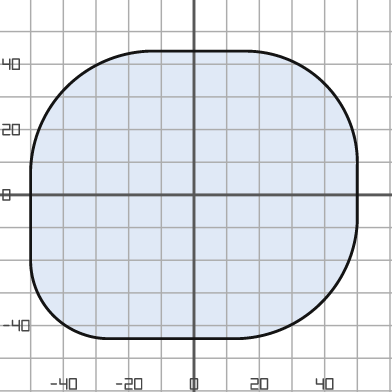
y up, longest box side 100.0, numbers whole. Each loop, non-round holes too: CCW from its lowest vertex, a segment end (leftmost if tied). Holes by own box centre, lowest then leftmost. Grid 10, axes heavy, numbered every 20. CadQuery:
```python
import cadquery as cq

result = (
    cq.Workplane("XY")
    .moveTo(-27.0, -44.0)
    .lineTo(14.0, -44.0)
    .threePointArc((39.0, -33.0), (50.0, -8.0))
    .lineTo(50.0, 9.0)
    .threePointArc((40.0, 34.0), (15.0, 44.0))
    .lineTo(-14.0, 44.0)
    .threePointArc((-39.0, 33.0), (-50.0, 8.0))
    .lineTo(-50.0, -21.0)
    .threePointArc((-43.0, -37.0), (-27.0, -44.0))
    .close()
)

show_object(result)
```